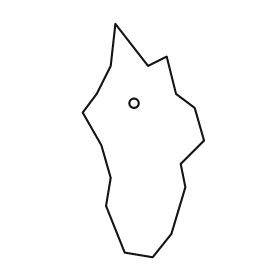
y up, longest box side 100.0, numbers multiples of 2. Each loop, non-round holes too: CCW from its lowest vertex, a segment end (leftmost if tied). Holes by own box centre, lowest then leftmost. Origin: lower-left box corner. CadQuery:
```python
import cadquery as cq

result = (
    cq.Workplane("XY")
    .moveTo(30.0, 0.0)
    .lineTo(38.0, 10.0)
    .lineTo(44.0, 30.0)
    .lineTo(42.0, 40.0)
    .lineTo(52.0, 50.0)
    .lineTo(48.0, 64.0)
    .lineTo(40.0, 70.0)
    .lineTo(36.0, 86.0)
    .lineTo(28.0, 82.0)
    .lineTo(14.0, 100.0)
    .lineTo(12.0, 82.0)
    .lineTo(6.0, 70.0)
    .lineTo(0.0, 62.0)
    .lineTo(8.0, 48.0)
    .lineTo(12.0, 34.0)
    .lineTo(10.0, 22.0)
    .lineTo(18.0, 2.0)
    .close()
    .moveTo(22.0, 66.0)
    .circle(2.0)
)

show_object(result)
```